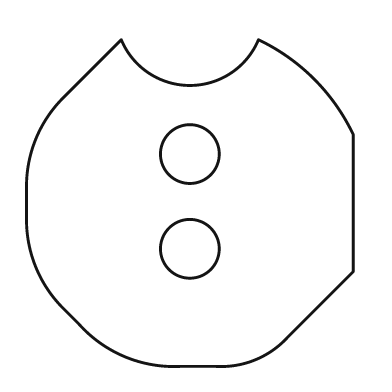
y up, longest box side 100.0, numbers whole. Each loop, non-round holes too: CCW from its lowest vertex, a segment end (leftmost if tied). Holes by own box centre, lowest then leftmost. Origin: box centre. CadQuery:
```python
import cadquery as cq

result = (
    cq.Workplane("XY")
    .moveTo(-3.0, -50.0)
    .lineTo(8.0, -50.0)
    .threePointArc((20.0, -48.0), (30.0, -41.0))
    .lineTo(50.0, -21.0)
    .lineTo(50.0, 21.0)
    .threePointArc((38.0, 38.0), (21.0, 50.0))
    .threePointArc((0.0, 36.0), (-21.0, 50.0))
    .lineTo(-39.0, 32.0)
    .threePointArc((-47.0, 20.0), (-50.0, 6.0))
    .lineTo(-50.0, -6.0)
    .threePointArc((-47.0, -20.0), (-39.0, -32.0))
    .lineTo(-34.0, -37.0)
    .threePointArc((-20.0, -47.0), (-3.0, -50.0))
    .close()
    .moveTo(0.0, -14.0)
    .circle(9.0)
    .moveTo(0.0, 15.0)
    .circle(9.0)
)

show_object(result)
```